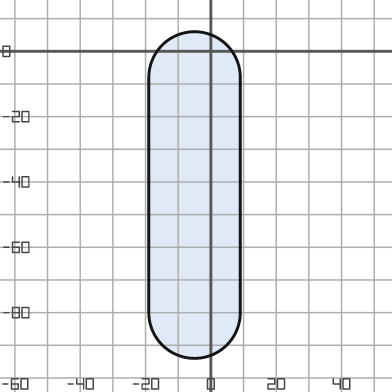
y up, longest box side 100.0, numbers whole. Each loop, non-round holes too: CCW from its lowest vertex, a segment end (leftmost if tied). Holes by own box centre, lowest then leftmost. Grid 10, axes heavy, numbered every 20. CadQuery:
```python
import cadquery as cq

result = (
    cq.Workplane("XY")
    .moveTo(-19.0, -80.0)
    .threePointArc((-5.0, -94.0), (9.0, -80.0))
    .lineTo(9.0, -8.0)
    .threePointArc((-5.0, 6.0), (-19.0, -8.0))
    .close()
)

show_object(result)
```